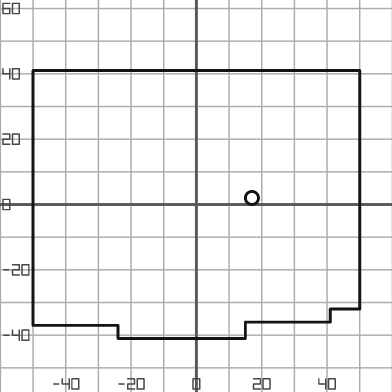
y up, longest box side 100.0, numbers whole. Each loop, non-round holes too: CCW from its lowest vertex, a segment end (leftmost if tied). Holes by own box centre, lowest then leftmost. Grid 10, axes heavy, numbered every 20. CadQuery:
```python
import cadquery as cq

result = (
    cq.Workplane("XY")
    .moveTo(-24.0, -41.0)
    .lineTo(15.0, -41.0)
    .lineTo(15.0, -36.0)
    .lineTo(41.0, -36.0)
    .lineTo(41.0, -32.0)
    .lineTo(50.0, -32.0)
    .lineTo(50.0, 41.0)
    .lineTo(-50.0, 41.0)
    .lineTo(-50.0, -37.0)
    .lineTo(-24.0, -37.0)
    .close()
    .moveTo(17.0, 2.0)
    .circle(2.0)
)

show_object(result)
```